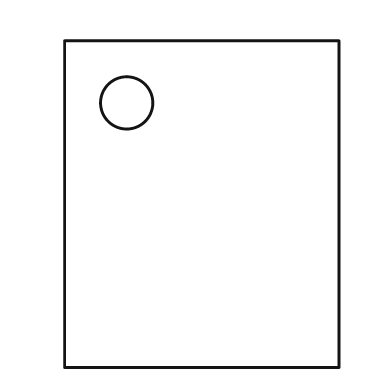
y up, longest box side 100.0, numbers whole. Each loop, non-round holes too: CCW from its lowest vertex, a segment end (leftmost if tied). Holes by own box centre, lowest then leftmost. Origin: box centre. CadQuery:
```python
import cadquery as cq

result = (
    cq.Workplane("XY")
    .moveTo(-42.0, -50.0)
    .lineTo(42.0, -50.0)
    .lineTo(42.0, 50.0)
    .lineTo(-42.0, 50.0)
    .close()
    .moveTo(-23.0, 31.0)
    .circle(8.0)
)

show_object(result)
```